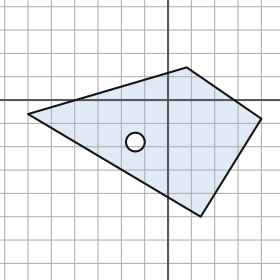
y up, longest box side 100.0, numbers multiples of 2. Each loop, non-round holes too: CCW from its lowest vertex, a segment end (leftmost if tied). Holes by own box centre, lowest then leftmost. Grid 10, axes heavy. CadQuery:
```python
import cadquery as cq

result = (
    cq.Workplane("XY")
    .moveTo(14.0, -50.0)
    .lineTo(40.0, -8.0)
    .lineTo(8.0, 14.0)
    .lineTo(-60.0, -6.0)
    .close()
    .moveTo(-14.0, -18.0)
    .circle(4.0)
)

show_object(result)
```